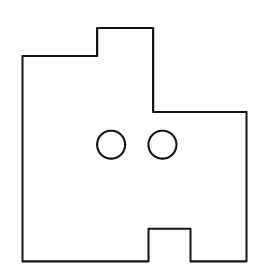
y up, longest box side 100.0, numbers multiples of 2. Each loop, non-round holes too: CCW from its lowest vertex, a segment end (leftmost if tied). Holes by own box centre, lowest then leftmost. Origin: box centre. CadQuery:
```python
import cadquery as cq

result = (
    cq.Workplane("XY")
    .moveTo(-48.0, -50.0)
    .lineTo(6.0, -50.0)
    .lineTo(6.0, -36.0)
    .lineTo(24.0, -36.0)
    .lineTo(24.0, -50.0)
    .lineTo(48.0, -50.0)
    .lineTo(48.0, 14.0)
    .lineTo(8.0, 14.0)
    .lineTo(8.0, 50.0)
    .lineTo(-16.0, 50.0)
    .lineTo(-16.0, 38.0)
    .lineTo(-48.0, 38.0)
    .close()
    .moveTo(-10.0, 0.0)
    .circle(6.0)
    .moveTo(12.0, 0.0)
    .circle(6.0)
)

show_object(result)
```